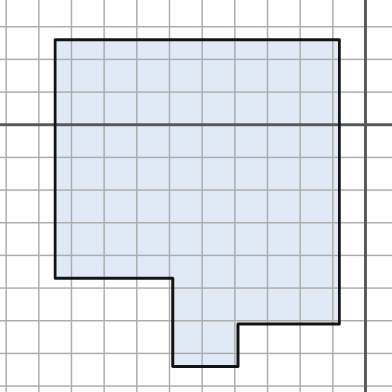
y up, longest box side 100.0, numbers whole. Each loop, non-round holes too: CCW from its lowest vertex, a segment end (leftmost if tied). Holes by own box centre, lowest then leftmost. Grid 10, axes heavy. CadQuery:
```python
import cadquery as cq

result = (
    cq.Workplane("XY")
    .moveTo(-59.0, -74.0)
    .lineTo(-39.0, -74.0)
    .lineTo(-39.0, -61.0)
    .lineTo(-8.0, -61.0)
    .lineTo(-8.0, 26.0)
    .lineTo(-95.0, 26.0)
    .lineTo(-95.0, -47.0)
    .lineTo(-59.0, -47.0)
    .close()
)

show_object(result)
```